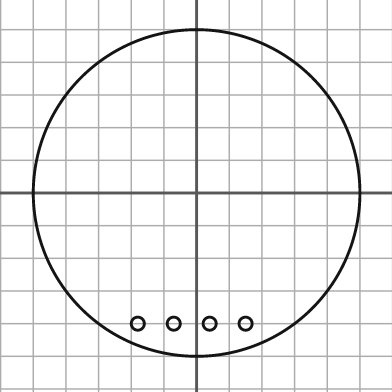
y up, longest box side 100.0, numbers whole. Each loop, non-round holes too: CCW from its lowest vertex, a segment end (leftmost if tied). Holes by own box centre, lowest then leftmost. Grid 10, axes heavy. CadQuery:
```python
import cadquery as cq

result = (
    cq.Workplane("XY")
    .moveTo(0.0, 0.0)
    .circle(50.0)
    .moveTo(-18.0, -40.0)
    .circle(2.0)
    .moveTo(-7.0, -40.0)
    .circle(2.0)
    .moveTo(4.0, -40.0)
    .circle(2.0)
    .moveTo(15.0, -40.0)
    .circle(2.0)
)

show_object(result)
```